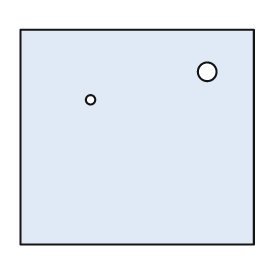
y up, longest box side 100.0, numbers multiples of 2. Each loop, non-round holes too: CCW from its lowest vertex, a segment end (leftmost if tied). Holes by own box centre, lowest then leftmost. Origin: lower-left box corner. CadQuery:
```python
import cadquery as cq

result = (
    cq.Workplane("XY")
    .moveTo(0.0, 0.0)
    .lineTo(100.0, 0.0)
    .lineTo(100.0, 92.0)
    .lineTo(0.0, 92.0)
    .close()
    .moveTo(30.0, 62.0)
    .circle(2.0)
    .moveTo(80.0, 74.0)
    .circle(4.0)
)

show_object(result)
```